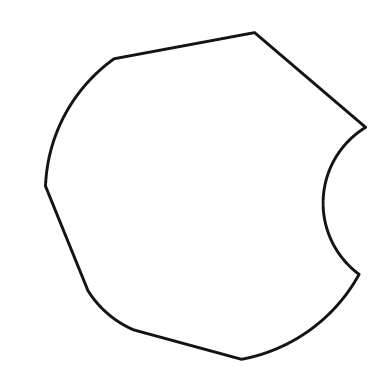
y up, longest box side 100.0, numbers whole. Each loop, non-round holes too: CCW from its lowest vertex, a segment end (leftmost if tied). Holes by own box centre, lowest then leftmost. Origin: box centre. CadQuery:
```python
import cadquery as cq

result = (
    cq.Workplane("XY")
    .moveTo(11.0, -50.0)
    .threePointArc((32.0, -41.0), (47.0, -24.0))
    .threePointArc((36.0, -1.0), (49.0, 21.0))
    .lineTo(15.0, 50.0)
    .lineTo(-28.0, 42.0)
    .threePointArc((-43.0, 25.0), (-49.0, 3.0))
    .lineTo(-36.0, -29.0)
    .threePointArc((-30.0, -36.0), (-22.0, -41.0))
    .close()
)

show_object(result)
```